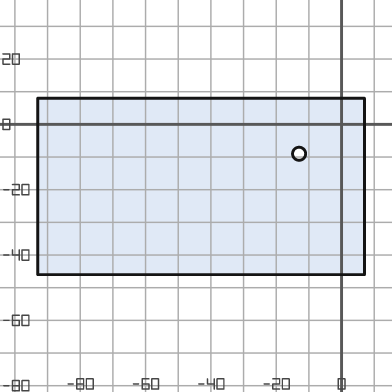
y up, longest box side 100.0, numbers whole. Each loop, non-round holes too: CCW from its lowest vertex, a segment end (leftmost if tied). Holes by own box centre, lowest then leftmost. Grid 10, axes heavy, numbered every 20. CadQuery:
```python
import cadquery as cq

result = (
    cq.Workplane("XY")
    .moveTo(-93.0, -46.0)
    .lineTo(7.0, -46.0)
    .lineTo(7.0, 8.0)
    .lineTo(-93.0, 8.0)
    .close()
    .moveTo(-13.0, -9.0)
    .circle(2.0)
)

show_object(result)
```